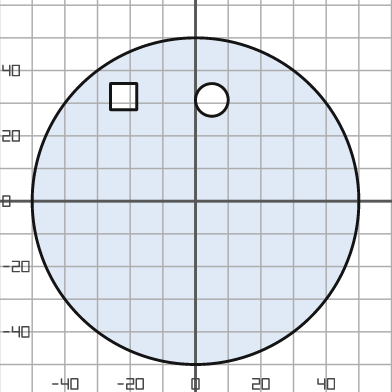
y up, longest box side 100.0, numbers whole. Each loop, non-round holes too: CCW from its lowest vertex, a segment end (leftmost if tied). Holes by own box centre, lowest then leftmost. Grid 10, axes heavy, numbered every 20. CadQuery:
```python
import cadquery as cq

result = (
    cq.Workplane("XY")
    .moveTo(0.0, 0.0)
    .circle(50.0)
    .moveTo(5.0, 31.0)
    .circle(5.0)
    .moveTo(-26.0, 28.0)
    .lineTo(-18.0, 28.0)
    .lineTo(-18.0, 36.0)
    .lineTo(-26.0, 36.0)
    .close()
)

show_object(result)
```